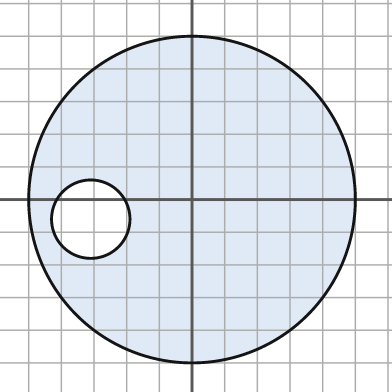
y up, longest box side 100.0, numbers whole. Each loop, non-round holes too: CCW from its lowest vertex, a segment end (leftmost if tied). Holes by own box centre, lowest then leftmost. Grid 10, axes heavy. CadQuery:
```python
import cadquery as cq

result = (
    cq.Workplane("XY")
    .moveTo(0.0, 0.0)
    .circle(50.0)
    .moveTo(-31.0, -6.0)
    .circle(12.0)
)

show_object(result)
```